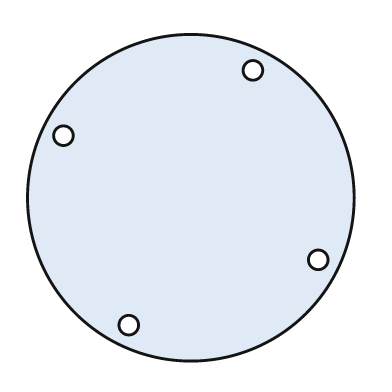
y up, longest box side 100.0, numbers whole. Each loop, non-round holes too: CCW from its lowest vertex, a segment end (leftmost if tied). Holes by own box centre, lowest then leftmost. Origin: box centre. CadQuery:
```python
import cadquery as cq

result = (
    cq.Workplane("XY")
    .moveTo(0.0, 0.0)
    .circle(50.0)
    .moveTo(-19.0, -39.0)
    .circle(3.0)
    .moveTo(39.0, -19.0)
    .circle(3.0)
    .moveTo(-39.0, 19.0)
    .circle(3.0)
    .moveTo(19.0, 39.0)
    .circle(3.0)
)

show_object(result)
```